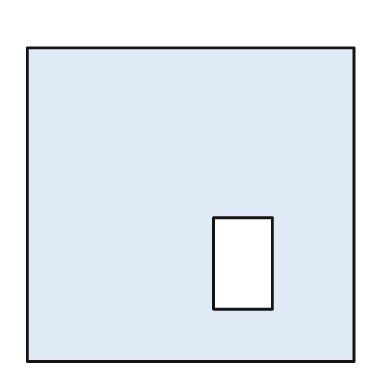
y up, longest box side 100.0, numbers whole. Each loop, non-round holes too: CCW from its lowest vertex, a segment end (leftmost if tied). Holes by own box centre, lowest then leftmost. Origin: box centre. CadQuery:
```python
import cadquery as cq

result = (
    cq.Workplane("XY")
    .moveTo(-50.0, -48.0)
    .lineTo(50.0, -48.0)
    .lineTo(50.0, 48.0)
    .lineTo(-50.0, 48.0)
    .close()
    .moveTo(7.0, -32.0)
    .lineTo(25.0, -32.0)
    .lineTo(25.0, -4.0)
    .lineTo(7.0, -4.0)
    .close()
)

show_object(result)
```